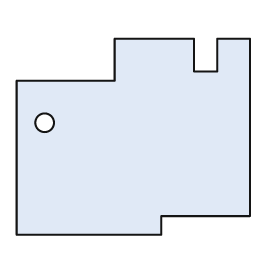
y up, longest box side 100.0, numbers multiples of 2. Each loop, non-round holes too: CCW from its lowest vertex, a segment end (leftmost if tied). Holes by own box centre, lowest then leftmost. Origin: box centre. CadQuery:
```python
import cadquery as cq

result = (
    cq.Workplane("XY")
    .moveTo(-50.0, -42.0)
    .lineTo(12.0, -42.0)
    .lineTo(12.0, -34.0)
    .lineTo(50.0, -34.0)
    .lineTo(50.0, 42.0)
    .lineTo(36.0, 42.0)
    .lineTo(36.0, 28.0)
    .lineTo(26.0, 28.0)
    .lineTo(26.0, 42.0)
    .lineTo(-8.0, 42.0)
    .lineTo(-8.0, 24.0)
    .lineTo(-50.0, 24.0)
    .close()
    .moveTo(-38.0, 6.0)
    .circle(4.0)
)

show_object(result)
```